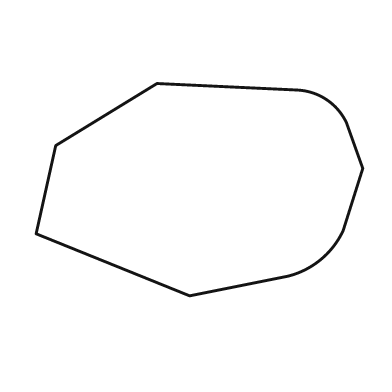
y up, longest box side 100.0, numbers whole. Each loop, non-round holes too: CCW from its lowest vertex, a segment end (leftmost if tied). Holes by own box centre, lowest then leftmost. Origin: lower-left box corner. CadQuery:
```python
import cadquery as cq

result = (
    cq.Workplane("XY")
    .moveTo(47.0, 0.0)
    .lineTo(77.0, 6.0)
    .threePointArc((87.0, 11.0), (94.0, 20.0))
    .lineTo(100.0, 39.0)
    .lineTo(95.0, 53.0)
    .threePointArc((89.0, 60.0), (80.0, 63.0))
    .lineTo(37.0, 65.0)
    .lineTo(6.0, 46.0)
    .lineTo(0.0, 19.0)
    .close()
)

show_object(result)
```